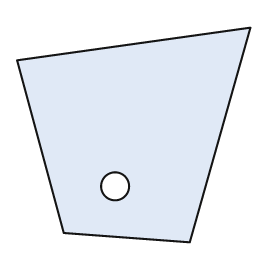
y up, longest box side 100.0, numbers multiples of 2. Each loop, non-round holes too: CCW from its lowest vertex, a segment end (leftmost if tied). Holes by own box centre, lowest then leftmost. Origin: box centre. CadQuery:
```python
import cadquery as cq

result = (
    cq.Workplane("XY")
    .moveTo(24.0, -46.0)
    .lineTo(50.0, 46.0)
    .lineTo(-50.0, 32.0)
    .lineTo(-30.0, -42.0)
    .close()
    .moveTo(-8.0, -22.0)
    .circle(6.0)
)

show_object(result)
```